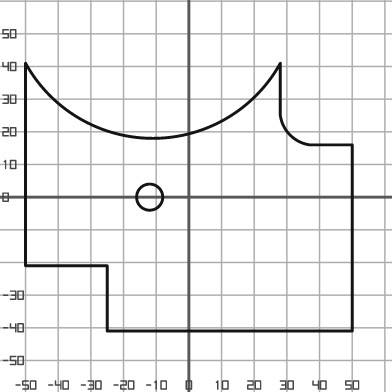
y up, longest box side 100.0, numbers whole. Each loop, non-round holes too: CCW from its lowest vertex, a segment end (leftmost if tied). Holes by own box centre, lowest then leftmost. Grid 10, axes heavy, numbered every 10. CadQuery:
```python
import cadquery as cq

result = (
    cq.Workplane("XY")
    .moveTo(-25.0, -41.0)
    .lineTo(50.0, -41.0)
    .lineTo(50.0, 16.0)
    .lineTo(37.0, 16.0)
    .threePointArc((31.0, 19.0), (28.0, 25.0))
    .lineTo(28.0, 41.0)
    .threePointArc((-11.0, 18.0), (-50.0, 41.0))
    .lineTo(-50.0, -21.0)
    .lineTo(-25.0, -21.0)
    .close()
    .moveTo(-12.0, 0.0)
    .circle(4.0)
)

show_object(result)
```